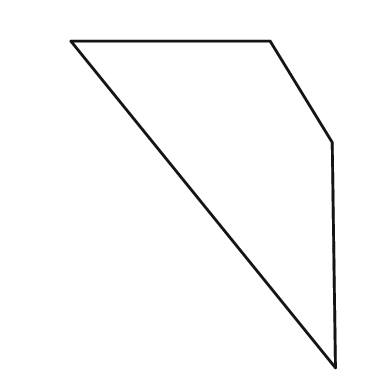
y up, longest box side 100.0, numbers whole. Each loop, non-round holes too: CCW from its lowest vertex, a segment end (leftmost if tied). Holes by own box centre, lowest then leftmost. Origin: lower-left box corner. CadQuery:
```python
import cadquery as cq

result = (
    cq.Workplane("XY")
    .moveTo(81.0, 0.0)
    .lineTo(80.0, 69.0)
    .lineTo(61.0, 100.0)
    .lineTo(0.0, 100.0)
    .close()
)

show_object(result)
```